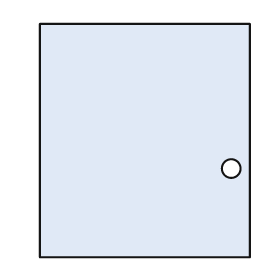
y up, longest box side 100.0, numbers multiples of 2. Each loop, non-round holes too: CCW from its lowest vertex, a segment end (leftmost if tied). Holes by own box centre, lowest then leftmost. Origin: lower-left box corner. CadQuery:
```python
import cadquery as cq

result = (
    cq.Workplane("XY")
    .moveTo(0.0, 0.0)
    .lineTo(90.0, 0.0)
    .lineTo(90.0, 100.0)
    .lineTo(0.0, 100.0)
    .close()
    .moveTo(82.0, 38.0)
    .circle(4.0)
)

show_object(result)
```